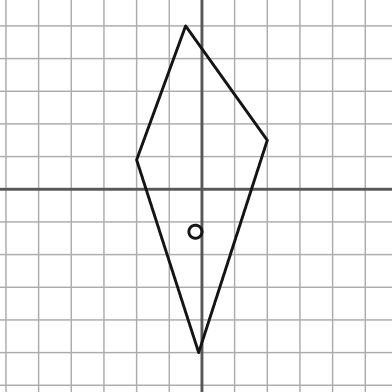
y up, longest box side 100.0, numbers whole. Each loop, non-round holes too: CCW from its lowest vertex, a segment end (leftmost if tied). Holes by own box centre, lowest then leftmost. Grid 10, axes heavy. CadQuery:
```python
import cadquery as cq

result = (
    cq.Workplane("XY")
    .moveTo(-1.0, -50.0)
    .lineTo(20.0, 15.0)
    .lineTo(-5.0, 50.0)
    .lineTo(-20.0, 9.0)
    .close()
    .moveTo(-2.0, -13.0)
    .circle(2.0)
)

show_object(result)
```